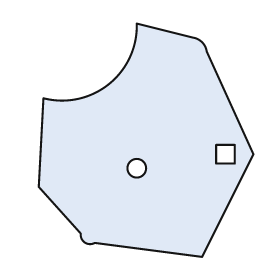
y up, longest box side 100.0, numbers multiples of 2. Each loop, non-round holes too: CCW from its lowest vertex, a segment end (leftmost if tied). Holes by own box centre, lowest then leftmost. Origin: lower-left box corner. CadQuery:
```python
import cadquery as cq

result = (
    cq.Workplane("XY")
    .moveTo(70.0, 0.0)
    .lineTo(92.0, 44.0)
    .lineTo(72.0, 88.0)
    .threePointArc((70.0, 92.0), (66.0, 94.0))
    .lineTo(42.0, 100.0)
    .threePointArc((30.0, 74.0), (2.0, 68.0))
    .lineTo(0.0, 30.0)
    .lineTo(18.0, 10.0)
    .threePointArc((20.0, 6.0), (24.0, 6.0))
    .close()
    .moveTo(42.0, 38.0)
    .circle(4.0)
    .moveTo(76.0, 40.0)
    .lineTo(84.0, 40.0)
    .lineTo(84.0, 48.0)
    .lineTo(76.0, 48.0)
    .close()
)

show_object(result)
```